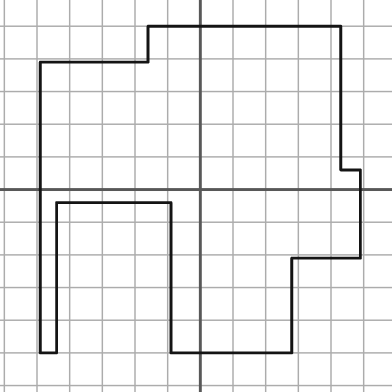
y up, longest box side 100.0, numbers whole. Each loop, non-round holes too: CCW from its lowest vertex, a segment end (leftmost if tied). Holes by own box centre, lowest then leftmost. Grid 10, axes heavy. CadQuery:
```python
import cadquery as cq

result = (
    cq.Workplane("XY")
    .moveTo(-49.0, -50.0)
    .lineTo(-44.0, -50.0)
    .lineTo(-44.0, -4.0)
    .lineTo(-9.0, -4.0)
    .lineTo(-9.0, -50.0)
    .lineTo(28.0, -50.0)
    .lineTo(28.0, -21.0)
    .lineTo(49.0, -21.0)
    .lineTo(49.0, 6.0)
    .lineTo(43.0, 6.0)
    .lineTo(43.0, 50.0)
    .lineTo(-16.0, 50.0)
    .lineTo(-16.0, 39.0)
    .lineTo(-49.0, 39.0)
    .close()
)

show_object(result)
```